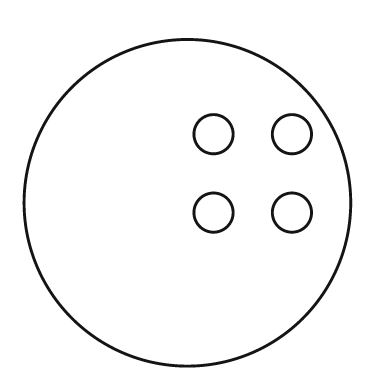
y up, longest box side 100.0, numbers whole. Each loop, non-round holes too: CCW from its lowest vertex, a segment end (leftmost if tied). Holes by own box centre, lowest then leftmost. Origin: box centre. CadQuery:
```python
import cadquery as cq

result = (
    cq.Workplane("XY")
    .moveTo(0.0, 0.0)
    .circle(50.0)
    .moveTo(8.0, -3.0)
    .circle(6.0)
    .moveTo(32.0, -3.0)
    .circle(6.0)
    .moveTo(8.0, 21.0)
    .circle(6.0)
    .moveTo(32.0, 21.0)
    .circle(6.0)
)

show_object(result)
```